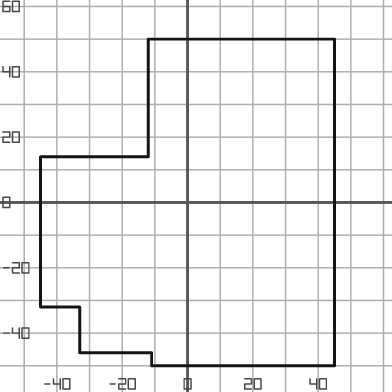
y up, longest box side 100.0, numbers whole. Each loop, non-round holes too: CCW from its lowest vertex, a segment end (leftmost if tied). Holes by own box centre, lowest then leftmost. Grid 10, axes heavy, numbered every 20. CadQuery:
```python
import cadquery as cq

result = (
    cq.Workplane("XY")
    .moveTo(-11.0, -50.0)
    .lineTo(45.0, -50.0)
    .lineTo(45.0, 50.0)
    .lineTo(-12.0, 50.0)
    .lineTo(-12.0, 14.0)
    .lineTo(-45.0, 14.0)
    .lineTo(-45.0, -32.0)
    .lineTo(-33.0, -32.0)
    .lineTo(-33.0, -46.0)
    .lineTo(-11.0, -46.0)
    .close()
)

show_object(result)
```